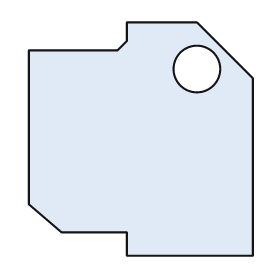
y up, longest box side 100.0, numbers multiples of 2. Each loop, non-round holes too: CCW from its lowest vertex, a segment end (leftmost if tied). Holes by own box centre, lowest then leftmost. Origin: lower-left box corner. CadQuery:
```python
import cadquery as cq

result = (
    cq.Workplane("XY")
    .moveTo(42.0, 0.0)
    .lineTo(96.0, 0.0)
    .lineTo(96.0, 76.0)
    .lineTo(72.0, 100.0)
    .lineTo(42.0, 100.0)
    .lineTo(42.0, 92.0)
    .lineTo(38.0, 88.0)
    .lineTo(0.0, 88.0)
    .lineTo(0.0, 22.0)
    .lineTo(14.0, 10.0)
    .lineTo(42.0, 10.0)
    .close()
    .moveTo(72.0, 80.0)
    .circle(10.0)
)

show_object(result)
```